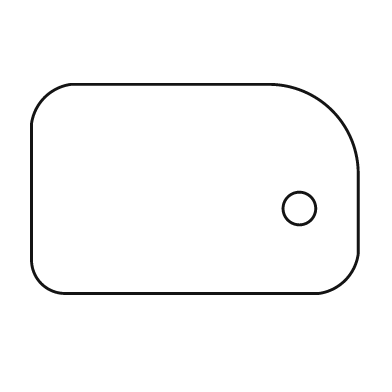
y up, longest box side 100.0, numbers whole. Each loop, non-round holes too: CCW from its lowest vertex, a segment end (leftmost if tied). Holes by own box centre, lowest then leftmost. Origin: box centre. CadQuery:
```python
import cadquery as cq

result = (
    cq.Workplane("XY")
    .moveTo(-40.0, -32.0)
    .lineTo(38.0, -32.0)
    .threePointArc((46.0, -28.0), (50.0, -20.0))
    .lineTo(50.0, 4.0)
    .threePointArc((42.0, 24.0), (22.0, 32.0))
    .lineTo(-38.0, 32.0)
    .threePointArc((-46.0, 28.0), (-50.0, 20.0))
    .lineTo(-50.0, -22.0)
    .threePointArc((-47.0, -29.0), (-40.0, -32.0))
    .close()
    .moveTo(32.0, -6.0)
    .circle(5.0)
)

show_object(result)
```